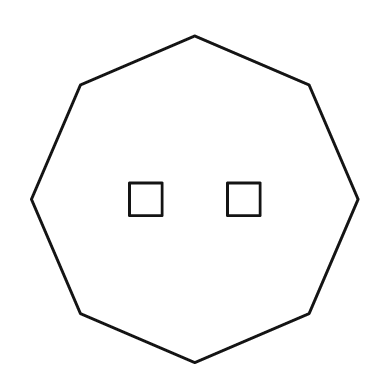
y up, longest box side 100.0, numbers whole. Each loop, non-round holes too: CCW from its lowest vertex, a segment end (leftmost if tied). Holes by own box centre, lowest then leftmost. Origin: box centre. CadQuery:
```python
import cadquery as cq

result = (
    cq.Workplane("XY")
    .moveTo(0.0, -50.0)
    .lineTo(35.0, -35.0)
    .lineTo(50.0, 0.0)
    .lineTo(35.0, 35.0)
    .lineTo(0.0, 50.0)
    .lineTo(-35.0, 35.0)
    .lineTo(-50.0, 0.0)
    .lineTo(-35.0, -35.0)
    .close()
    .moveTo(-20.0, -5.0)
    .lineTo(-10.0, -5.0)
    .lineTo(-10.0, 5.0)
    .lineTo(-20.0, 5.0)
    .close()
    .moveTo(10.0, -5.0)
    .lineTo(20.0, -5.0)
    .lineTo(20.0, 5.0)
    .lineTo(10.0, 5.0)
    .close()
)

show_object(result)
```